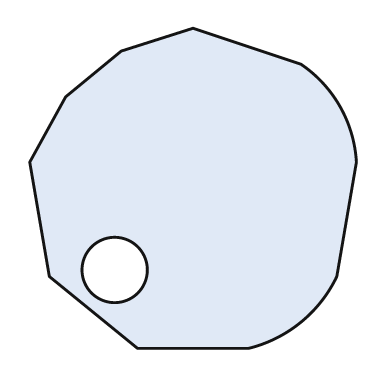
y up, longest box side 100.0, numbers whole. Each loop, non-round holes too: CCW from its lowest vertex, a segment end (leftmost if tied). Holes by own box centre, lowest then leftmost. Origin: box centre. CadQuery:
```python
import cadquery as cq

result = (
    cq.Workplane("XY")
    .moveTo(-17.0, -49.0)
    .lineTo(17.0, -49.0)
    .threePointArc((33.0, -41.0), (44.0, -27.0))
    .lineTo(50.0, 8.0)
    .threePointArc((45.0, 25.0), (33.0, 38.0))
    .lineTo(0.0, 49.0)
    .lineTo(-22.0, 42.0)
    .lineTo(-39.0, 28.0)
    .lineTo(-50.0, 8.0)
    .lineTo(-44.0, -27.0)
    .close()
    .moveTo(-24.0, -25.0)
    .circle(10.0)
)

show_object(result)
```